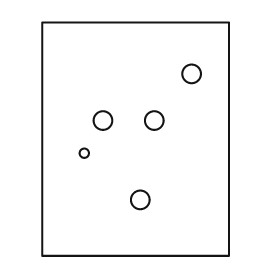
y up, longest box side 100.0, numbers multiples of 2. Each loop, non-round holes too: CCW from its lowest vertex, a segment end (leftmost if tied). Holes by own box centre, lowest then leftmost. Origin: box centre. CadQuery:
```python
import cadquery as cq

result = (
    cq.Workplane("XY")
    .moveTo(-40.0, -50.0)
    .lineTo(40.0, -50.0)
    .lineTo(40.0, 50.0)
    .lineTo(-40.0, 50.0)
    .close()
    .moveTo(2.0, -26.0)
    .circle(4.0)
    .moveTo(-22.0, -6.0)
    .circle(2.0)
    .moveTo(-14.0, 8.0)
    .circle(4.0)
    .moveTo(8.0, 8.0)
    .circle(4.0)
    .moveTo(24.0, 28.0)
    .circle(4.0)
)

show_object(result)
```